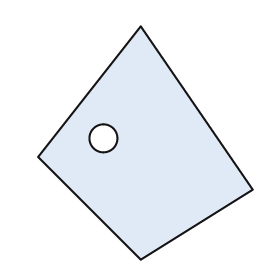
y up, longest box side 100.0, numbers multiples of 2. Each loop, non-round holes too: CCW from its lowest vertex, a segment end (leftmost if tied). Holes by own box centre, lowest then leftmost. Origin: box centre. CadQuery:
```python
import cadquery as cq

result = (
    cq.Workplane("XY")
    .moveTo(-2.0, -50.0)
    .lineTo(46.0, -20.0)
    .lineTo(-2.0, 50.0)
    .lineTo(-46.0, -6.0)
    .close()
    .moveTo(-18.0, 2.0)
    .circle(6.0)
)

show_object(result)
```